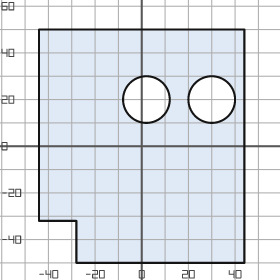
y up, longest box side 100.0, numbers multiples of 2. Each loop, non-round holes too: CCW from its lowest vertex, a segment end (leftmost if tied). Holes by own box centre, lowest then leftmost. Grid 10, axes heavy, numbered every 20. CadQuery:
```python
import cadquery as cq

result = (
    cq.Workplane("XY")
    .moveTo(-28.0, -50.0)
    .lineTo(44.0, -50.0)
    .lineTo(44.0, 50.0)
    .lineTo(-44.0, 50.0)
    .lineTo(-44.0, -32.0)
    .lineTo(-28.0, -32.0)
    .close()
    .moveTo(2.0, 20.0)
    .circle(10.0)
    .moveTo(30.0, 20.0)
    .circle(10.0)
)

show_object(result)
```